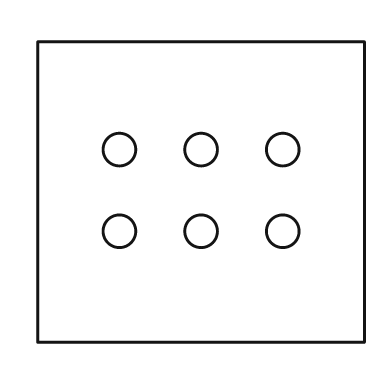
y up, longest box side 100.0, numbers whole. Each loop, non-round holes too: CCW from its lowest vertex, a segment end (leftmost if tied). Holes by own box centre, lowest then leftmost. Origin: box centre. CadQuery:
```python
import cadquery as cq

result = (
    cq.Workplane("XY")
    .moveTo(-50.0, -46.0)
    .lineTo(50.0, -46.0)
    .lineTo(50.0, 46.0)
    .lineTo(-50.0, 46.0)
    .close()
    .moveTo(-25.0, -12.0)
    .circle(5.0)
    .moveTo(0.0, -12.0)
    .circle(5.0)
    .moveTo(25.0, -12.0)
    .circle(5.0)
    .moveTo(-25.0, 13.0)
    .circle(5.0)
    .moveTo(0.0, 13.0)
    .circle(5.0)
    .moveTo(25.0, 13.0)
    .circle(5.0)
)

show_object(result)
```